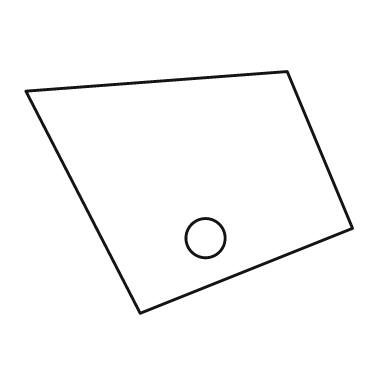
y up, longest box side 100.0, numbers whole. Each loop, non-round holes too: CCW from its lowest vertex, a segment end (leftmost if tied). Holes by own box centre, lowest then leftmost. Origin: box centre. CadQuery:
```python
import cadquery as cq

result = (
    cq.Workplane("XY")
    .moveTo(-15.0, -37.0)
    .lineTo(50.0, -11.0)
    .lineTo(30.0, 37.0)
    .lineTo(-50.0, 31.0)
    .close()
    .moveTo(5.0, -14.0)
    .circle(6.0)
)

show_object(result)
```